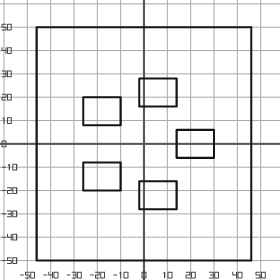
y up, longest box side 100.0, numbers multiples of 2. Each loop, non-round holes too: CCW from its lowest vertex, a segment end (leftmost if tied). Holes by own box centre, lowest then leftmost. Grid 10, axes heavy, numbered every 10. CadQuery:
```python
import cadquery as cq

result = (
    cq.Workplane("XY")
    .moveTo(-46.0, -50.0)
    .lineTo(46.0, -50.0)
    .lineTo(46.0, 50.0)
    .lineTo(-46.0, 50.0)
    .close()
    .moveTo(-2.0, -28.0)
    .lineTo(14.0, -28.0)
    .lineTo(14.0, -16.0)
    .lineTo(-2.0, -16.0)
    .close()
    .moveTo(-26.0, -20.0)
    .lineTo(-10.0, -20.0)
    .lineTo(-10.0, -8.0)
    .lineTo(-26.0, -8.0)
    .close()
    .moveTo(14.0, -6.0)
    .lineTo(30.0, -6.0)
    .lineTo(30.0, 6.0)
    .lineTo(14.0, 6.0)
    .close()
    .moveTo(-26.0, 8.0)
    .lineTo(-10.0, 8.0)
    .lineTo(-10.0, 20.0)
    .lineTo(-26.0, 20.0)
    .close()
    .moveTo(-2.0, 16.0)
    .lineTo(14.0, 16.0)
    .lineTo(14.0, 28.0)
    .lineTo(-2.0, 28.0)
    .close()
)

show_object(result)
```